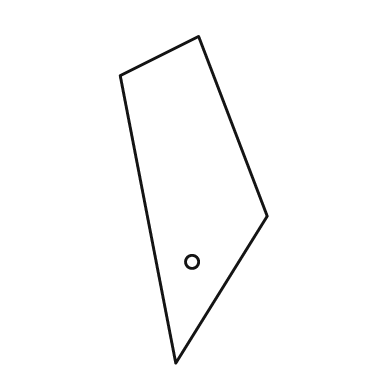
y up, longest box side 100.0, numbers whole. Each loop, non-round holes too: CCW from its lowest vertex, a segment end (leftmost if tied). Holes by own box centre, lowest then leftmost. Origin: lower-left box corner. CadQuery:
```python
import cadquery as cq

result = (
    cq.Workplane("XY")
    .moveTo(17.0, 0.0)
    .lineTo(45.0, 45.0)
    .lineTo(24.0, 100.0)
    .lineTo(0.0, 88.0)
    .close()
    .moveTo(22.0, 31.0)
    .circle(2.0)
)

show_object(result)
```